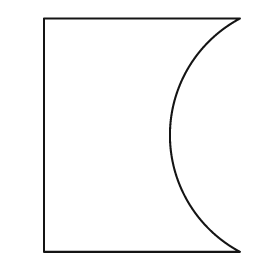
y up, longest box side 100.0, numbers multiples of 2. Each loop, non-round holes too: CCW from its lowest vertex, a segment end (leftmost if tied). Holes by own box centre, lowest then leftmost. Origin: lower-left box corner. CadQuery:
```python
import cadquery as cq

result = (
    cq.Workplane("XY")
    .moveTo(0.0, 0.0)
    .lineTo(84.0, 0.0)
    .threePointArc((54.0, 50.0), (84.0, 100.0))
    .lineTo(0.0, 100.0)
    .close()
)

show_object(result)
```